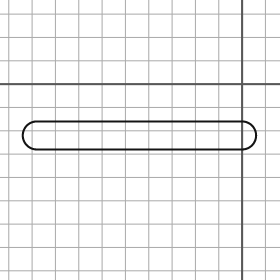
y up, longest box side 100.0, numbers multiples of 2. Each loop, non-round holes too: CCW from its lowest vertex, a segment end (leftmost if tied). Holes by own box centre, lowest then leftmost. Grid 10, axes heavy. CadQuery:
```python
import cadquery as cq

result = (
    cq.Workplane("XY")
    .moveTo(-88.0, -28.0)
    .lineTo(0.0, -28.0)
    .threePointArc((6.0, -22.0), (0.0, -16.0))
    .lineTo(-88.0, -16.0)
    .threePointArc((-94.0, -22.0), (-88.0, -28.0))
    .close()
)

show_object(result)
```